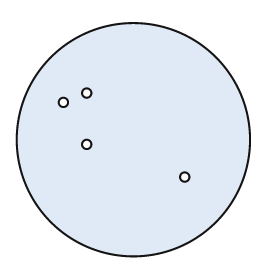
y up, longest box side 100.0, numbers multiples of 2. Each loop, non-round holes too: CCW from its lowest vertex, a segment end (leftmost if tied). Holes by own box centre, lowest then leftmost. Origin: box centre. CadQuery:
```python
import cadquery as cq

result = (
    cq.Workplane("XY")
    .moveTo(0.0, 0.0)
    .circle(50.0)
    .moveTo(22.0, -16.0)
    .circle(2.0)
    .moveTo(-20.0, -2.0)
    .circle(2.0)
    .moveTo(-30.0, 16.0)
    .circle(2.0)
    .moveTo(-20.0, 20.0)
    .circle(2.0)
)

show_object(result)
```